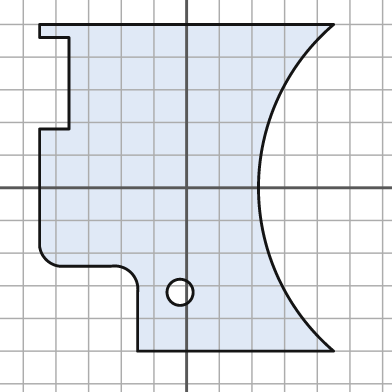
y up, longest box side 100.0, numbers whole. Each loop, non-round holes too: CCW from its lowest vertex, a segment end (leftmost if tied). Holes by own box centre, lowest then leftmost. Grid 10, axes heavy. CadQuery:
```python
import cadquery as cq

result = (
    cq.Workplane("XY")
    .moveTo(-15.0, -50.0)
    .lineTo(45.0, -50.0)
    .threePointArc((22.0, 0.0), (45.0, 50.0))
    .lineTo(-45.0, 50.0)
    .lineTo(-45.0, 46.0)
    .lineTo(-36.0, 46.0)
    .lineTo(-36.0, 18.0)
    .lineTo(-45.0, 18.0)
    .lineTo(-45.0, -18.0)
    .threePointArc((-43.0, -22.0), (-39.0, -24.0))
    .lineTo(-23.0, -24.0)
    .threePointArc((-17.0, -26.0), (-15.0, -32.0))
    .close()
    .moveTo(-2.0, -32.0)
    .circle(4.0)
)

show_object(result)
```